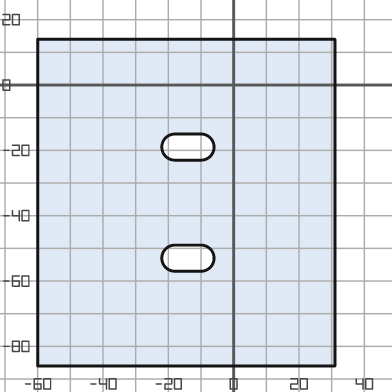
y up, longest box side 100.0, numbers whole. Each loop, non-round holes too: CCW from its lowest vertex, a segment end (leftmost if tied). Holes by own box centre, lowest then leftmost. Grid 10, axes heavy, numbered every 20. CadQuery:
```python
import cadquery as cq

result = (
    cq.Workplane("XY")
    .moveTo(-60.0, -86.0)
    .lineTo(31.0, -86.0)
    .lineTo(31.0, 14.0)
    .lineTo(-60.0, 14.0)
    .close()
    .moveTo(-18.0, -57.0)
    .lineTo(-10.0, -57.0)
    .threePointArc((-6.0, -53.0), (-10.0, -49.0))
    .lineTo(-18.0, -49.0)
    .threePointArc((-22.0, -53.0), (-18.0, -57.0))
    .close()
    .moveTo(-18.0, -23.0)
    .lineTo(-10.0, -23.0)
    .threePointArc((-6.0, -19.0), (-10.0, -15.0))
    .lineTo(-18.0, -15.0)
    .threePointArc((-22.0, -19.0), (-18.0, -23.0))
    .close()
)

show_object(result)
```